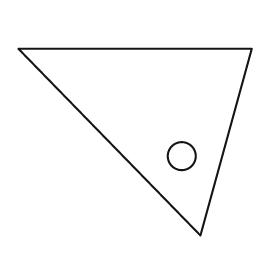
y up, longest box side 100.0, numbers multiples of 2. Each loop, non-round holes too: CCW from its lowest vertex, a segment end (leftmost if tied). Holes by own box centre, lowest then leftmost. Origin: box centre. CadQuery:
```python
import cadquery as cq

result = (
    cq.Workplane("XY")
    .moveTo(28.0, -40.0)
    .lineTo(50.0, 40.0)
    .lineTo(-50.0, 40.0)
    .close()
    .moveTo(20.0, -6.0)
    .circle(6.0)
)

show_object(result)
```